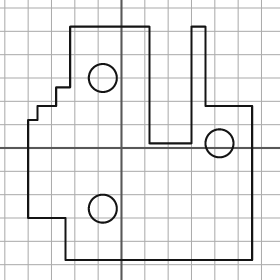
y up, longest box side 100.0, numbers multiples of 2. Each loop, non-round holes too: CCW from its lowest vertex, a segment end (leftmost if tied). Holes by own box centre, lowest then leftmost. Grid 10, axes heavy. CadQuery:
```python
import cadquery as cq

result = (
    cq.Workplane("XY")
    .moveTo(-24.0, -48.0)
    .lineTo(56.0, -48.0)
    .lineTo(56.0, 18.0)
    .lineTo(36.0, 18.0)
    .lineTo(36.0, 52.0)
    .lineTo(30.0, 52.0)
    .lineTo(30.0, 2.0)
    .lineTo(12.0, 2.0)
    .lineTo(12.0, 52.0)
    .lineTo(-22.0, 52.0)
    .lineTo(-22.0, 26.0)
    .lineTo(-28.0, 26.0)
    .lineTo(-28.0, 18.0)
    .lineTo(-36.0, 18.0)
    .lineTo(-36.0, 12.0)
    .lineTo(-40.0, 12.0)
    .lineTo(-40.0, -30.0)
    .lineTo(-24.0, -30.0)
    .close()
    .moveTo(-8.0, -26.0)
    .circle(6.0)
    .moveTo(42.0, 2.0)
    .circle(6.0)
    .moveTo(-8.0, 30.0)
    .circle(6.0)
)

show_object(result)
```